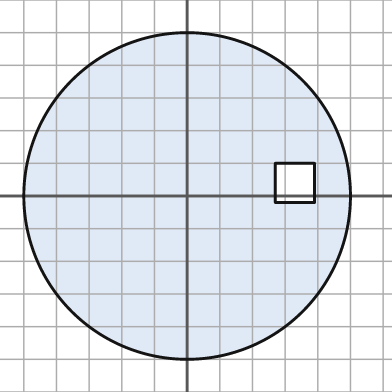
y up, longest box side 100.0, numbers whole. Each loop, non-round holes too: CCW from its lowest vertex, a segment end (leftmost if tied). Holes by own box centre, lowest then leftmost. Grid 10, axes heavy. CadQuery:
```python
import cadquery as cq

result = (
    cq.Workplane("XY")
    .moveTo(0.0, 0.0)
    .circle(50.0)
    .moveTo(27.0, -2.0)
    .lineTo(39.0, -2.0)
    .lineTo(39.0, 10.0)
    .lineTo(27.0, 10.0)
    .close()
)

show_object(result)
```